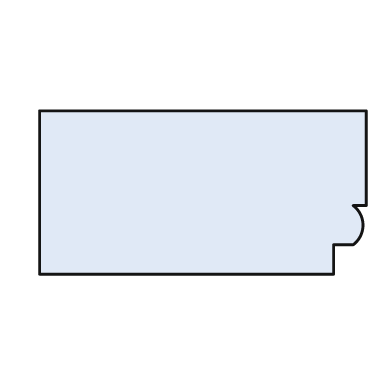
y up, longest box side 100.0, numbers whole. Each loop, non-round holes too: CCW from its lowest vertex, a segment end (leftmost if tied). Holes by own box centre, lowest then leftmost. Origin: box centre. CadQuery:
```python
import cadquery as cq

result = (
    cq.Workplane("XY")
    .moveTo(-50.0, -25.0)
    .lineTo(40.0, -25.0)
    .lineTo(40.0, -16.0)
    .lineTo(46.0, -16.0)
    .threePointArc((49.0, -10.0), (46.0, -4.0))
    .lineTo(50.0, -4.0)
    .lineTo(50.0, 25.0)
    .lineTo(-50.0, 25.0)
    .close()
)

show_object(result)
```